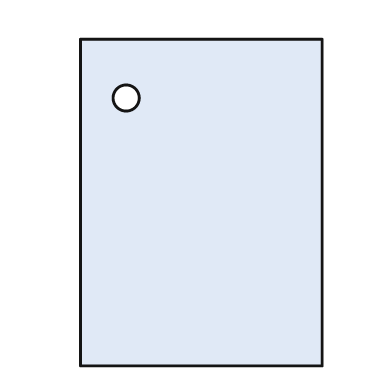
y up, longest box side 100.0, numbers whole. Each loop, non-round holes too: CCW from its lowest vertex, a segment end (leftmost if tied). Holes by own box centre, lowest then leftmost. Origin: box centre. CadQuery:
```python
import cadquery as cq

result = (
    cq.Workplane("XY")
    .moveTo(-37.0, -50.0)
    .lineTo(37.0, -50.0)
    .lineTo(37.0, 50.0)
    .lineTo(-37.0, 50.0)
    .close()
    .moveTo(-23.0, 32.0)
    .circle(4.0)
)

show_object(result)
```